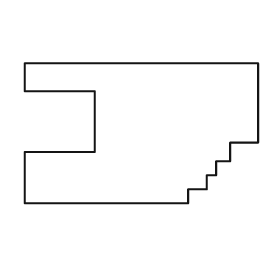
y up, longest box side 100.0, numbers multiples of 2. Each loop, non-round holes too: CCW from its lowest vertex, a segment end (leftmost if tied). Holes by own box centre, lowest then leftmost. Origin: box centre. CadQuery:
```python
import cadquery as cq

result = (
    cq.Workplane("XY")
    .moveTo(-50.0, -30.0)
    .lineTo(20.0, -30.0)
    .lineTo(20.0, -24.0)
    .lineTo(28.0, -24.0)
    .lineTo(28.0, -18.0)
    .lineTo(32.0, -18.0)
    .lineTo(32.0, -12.0)
    .lineTo(38.0, -12.0)
    .lineTo(38.0, -4.0)
    .lineTo(50.0, -4.0)
    .lineTo(50.0, 30.0)
    .lineTo(-50.0, 30.0)
    .lineTo(-50.0, 18.0)
    .lineTo(-20.0, 18.0)
    .lineTo(-20.0, -8.0)
    .lineTo(-50.0, -8.0)
    .close()
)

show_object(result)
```